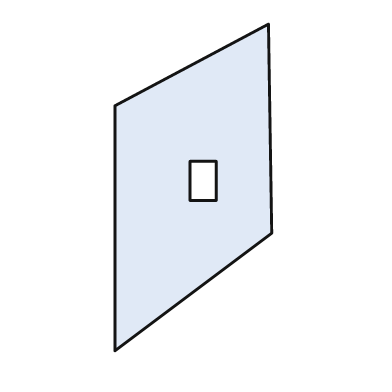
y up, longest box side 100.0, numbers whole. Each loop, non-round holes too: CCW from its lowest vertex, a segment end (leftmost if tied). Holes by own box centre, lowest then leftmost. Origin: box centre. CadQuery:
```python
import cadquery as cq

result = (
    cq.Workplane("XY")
    .moveTo(-24.0, -50.0)
    .lineTo(24.0, -14.0)
    .lineTo(23.0, 50.0)
    .lineTo(-24.0, 25.0)
    .close()
    .moveTo(-1.0, -4.0)
    .lineTo(7.0, -4.0)
    .lineTo(7.0, 8.0)
    .lineTo(-1.0, 8.0)
    .close()
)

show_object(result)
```